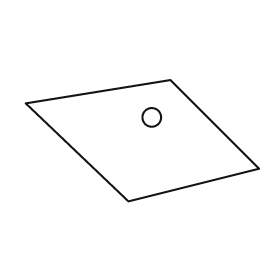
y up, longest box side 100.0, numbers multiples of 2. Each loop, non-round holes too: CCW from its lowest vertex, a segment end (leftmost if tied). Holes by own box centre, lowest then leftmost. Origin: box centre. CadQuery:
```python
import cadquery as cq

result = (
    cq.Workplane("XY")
    .moveTo(-6.0, -26.0)
    .lineTo(50.0, -12.0)
    .lineTo(12.0, 26.0)
    .lineTo(-50.0, 16.0)
    .close()
    .moveTo(4.0, 10.0)
    .circle(4.0)
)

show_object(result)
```